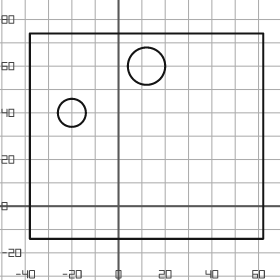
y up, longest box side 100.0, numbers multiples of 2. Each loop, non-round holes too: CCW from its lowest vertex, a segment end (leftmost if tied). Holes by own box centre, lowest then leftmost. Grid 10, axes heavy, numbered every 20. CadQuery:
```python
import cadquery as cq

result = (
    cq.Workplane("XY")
    .moveTo(-38.0, -14.0)
    .lineTo(62.0, -14.0)
    .lineTo(62.0, 74.0)
    .lineTo(-38.0, 74.0)
    .close()
    .moveTo(-20.0, 40.0)
    .circle(6.0)
    .moveTo(12.0, 60.0)
    .circle(8.0)
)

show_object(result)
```